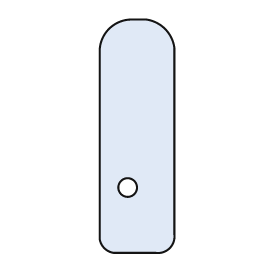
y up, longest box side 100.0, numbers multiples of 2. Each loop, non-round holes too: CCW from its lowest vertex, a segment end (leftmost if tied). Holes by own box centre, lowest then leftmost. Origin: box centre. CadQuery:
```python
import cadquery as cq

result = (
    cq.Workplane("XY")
    .moveTo(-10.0, -50.0)
    .lineTo(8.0, -50.0)
    .threePointArc((14.0, -48.0), (16.0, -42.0))
    .lineTo(16.0, 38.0)
    .threePointArc((12.0, 46.0), (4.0, 50.0))
    .lineTo(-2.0, 50.0)
    .threePointArc((-12.0, 46.0), (-16.0, 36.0))
    .lineTo(-16.0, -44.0)
    .threePointArc((-14.0, -48.0), (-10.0, -50.0))
    .close()
    .moveTo(-4.0, -22.0)
    .circle(4.0)
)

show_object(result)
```